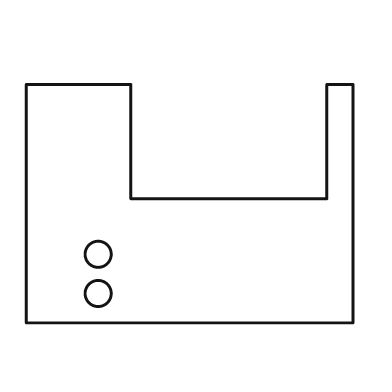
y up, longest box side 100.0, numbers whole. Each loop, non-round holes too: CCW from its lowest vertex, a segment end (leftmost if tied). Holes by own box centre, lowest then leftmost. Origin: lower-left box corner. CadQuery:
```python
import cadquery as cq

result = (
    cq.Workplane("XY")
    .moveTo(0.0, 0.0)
    .lineTo(100.0, 0.0)
    .lineTo(100.0, 73.0)
    .lineTo(92.0, 73.0)
    .lineTo(92.0, 38.0)
    .lineTo(32.0, 38.0)
    .lineTo(32.0, 73.0)
    .lineTo(0.0, 73.0)
    .close()
    .moveTo(22.0, 9.0)
    .circle(4.0)
    .moveTo(22.0, 21.0)
    .circle(4.0)
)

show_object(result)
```